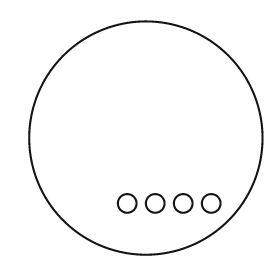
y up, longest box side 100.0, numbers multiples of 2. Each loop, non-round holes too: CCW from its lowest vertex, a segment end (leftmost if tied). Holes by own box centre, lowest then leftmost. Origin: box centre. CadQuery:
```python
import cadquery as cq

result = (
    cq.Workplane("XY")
    .moveTo(0.0, 0.0)
    .circle(50.0)
    .moveTo(-8.0, -28.0)
    .circle(4.0)
    .moveTo(4.0, -28.0)
    .circle(4.0)
    .moveTo(16.0, -28.0)
    .circle(4.0)
    .moveTo(28.0, -28.0)
    .circle(4.0)
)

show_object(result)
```